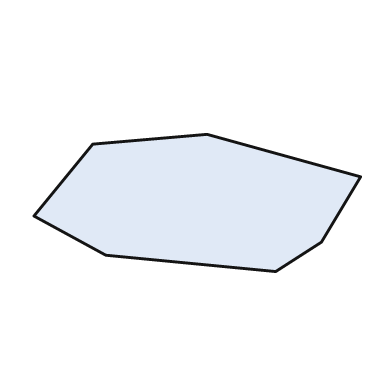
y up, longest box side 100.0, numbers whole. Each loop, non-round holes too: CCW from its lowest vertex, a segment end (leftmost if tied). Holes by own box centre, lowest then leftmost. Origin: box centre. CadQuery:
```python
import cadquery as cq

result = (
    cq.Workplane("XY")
    .moveTo(24.0, -21.0)
    .lineTo(38.0, -12.0)
    .lineTo(50.0, 8.0)
    .lineTo(3.0, 21.0)
    .lineTo(-32.0, 18.0)
    .lineTo(-50.0, -4.0)
    .lineTo(-28.0, -16.0)
    .close()
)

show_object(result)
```